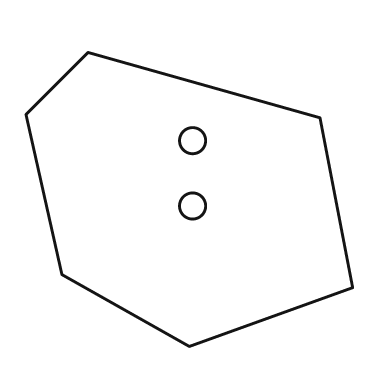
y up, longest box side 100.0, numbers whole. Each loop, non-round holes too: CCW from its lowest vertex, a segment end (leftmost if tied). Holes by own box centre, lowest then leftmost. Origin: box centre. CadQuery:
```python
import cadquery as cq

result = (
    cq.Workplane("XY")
    .moveTo(0.0, -45.0)
    .lineTo(50.0, -27.0)
    .lineTo(40.0, 25.0)
    .lineTo(-31.0, 45.0)
    .lineTo(-50.0, 26.0)
    .lineTo(-39.0, -23.0)
    .close()
    .moveTo(1.0, -2.0)
    .circle(4.0)
    .moveTo(1.0, 18.0)
    .circle(4.0)
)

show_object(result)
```